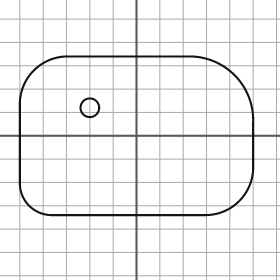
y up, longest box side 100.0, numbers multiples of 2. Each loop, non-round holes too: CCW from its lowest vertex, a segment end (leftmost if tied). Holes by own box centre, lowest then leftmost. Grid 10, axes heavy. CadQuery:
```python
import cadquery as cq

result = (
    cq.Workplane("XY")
    .moveTo(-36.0, -34.0)
    .lineTo(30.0, -34.0)
    .threePointArc((44.0, -28.0), (50.0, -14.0))
    .lineTo(50.0, 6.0)
    .threePointArc((42.0, 26.0), (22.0, 34.0))
    .lineTo(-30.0, 34.0)
    .threePointArc((-44.0, 28.0), (-50.0, 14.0))
    .lineTo(-50.0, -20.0)
    .threePointArc((-46.0, -30.0), (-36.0, -34.0))
    .close()
    .moveTo(-20.0, 12.0)
    .circle(4.0)
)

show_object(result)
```